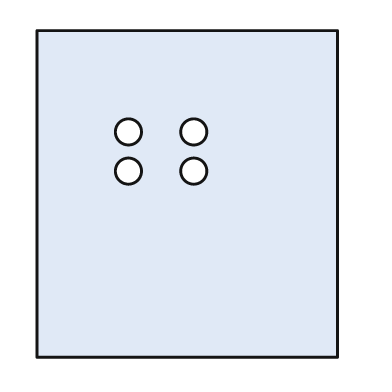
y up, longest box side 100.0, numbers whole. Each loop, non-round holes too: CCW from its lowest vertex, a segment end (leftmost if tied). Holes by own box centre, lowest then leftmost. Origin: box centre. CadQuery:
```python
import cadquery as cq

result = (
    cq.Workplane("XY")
    .moveTo(-46.0, -50.0)
    .lineTo(46.0, -50.0)
    .lineTo(46.0, 50.0)
    .lineTo(-46.0, 50.0)
    .close()
    .moveTo(-18.0, 7.0)
    .circle(4.0)
    .moveTo(2.0, 7.0)
    .circle(4.0)
    .moveTo(-18.0, 19.0)
    .circle(4.0)
    .moveTo(2.0, 19.0)
    .circle(4.0)
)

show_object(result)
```